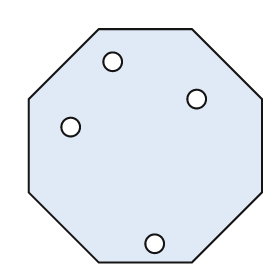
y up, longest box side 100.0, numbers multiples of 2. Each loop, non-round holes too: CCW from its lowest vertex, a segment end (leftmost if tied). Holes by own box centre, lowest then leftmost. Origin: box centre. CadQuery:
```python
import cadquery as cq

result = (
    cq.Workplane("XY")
    .moveTo(-20.0, -50.0)
    .lineTo(20.0, -50.0)
    .lineTo(50.0, -20.0)
    .lineTo(50.0, 20.0)
    .lineTo(20.0, 50.0)
    .lineTo(-20.0, 50.0)
    .lineTo(-50.0, 20.0)
    .lineTo(-50.0, -20.0)
    .close()
    .moveTo(4.0, -42.0)
    .circle(4.0)
    .moveTo(-32.0, 8.0)
    .circle(4.0)
    .moveTo(22.0, 20.0)
    .circle(4.0)
    .moveTo(-14.0, 36.0)
    .circle(4.0)
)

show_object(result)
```